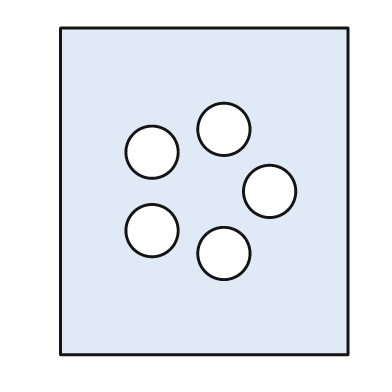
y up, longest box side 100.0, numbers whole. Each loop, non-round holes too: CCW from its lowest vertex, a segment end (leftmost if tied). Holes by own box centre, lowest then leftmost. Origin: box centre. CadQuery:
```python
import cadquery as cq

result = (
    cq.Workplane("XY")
    .moveTo(-44.0, -50.0)
    .lineTo(44.0, -50.0)
    .lineTo(44.0, 50.0)
    .lineTo(-44.0, 50.0)
    .close()
    .moveTo(6.0, -19.0)
    .circle(8.0)
    .moveTo(-16.0, -12.0)
    .circle(8.0)
    .moveTo(20.0, 0.0)
    .circle(8.0)
    .moveTo(-16.0, 12.0)
    .circle(8.0)
    .moveTo(6.0, 19.0)
    .circle(8.0)
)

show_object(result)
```